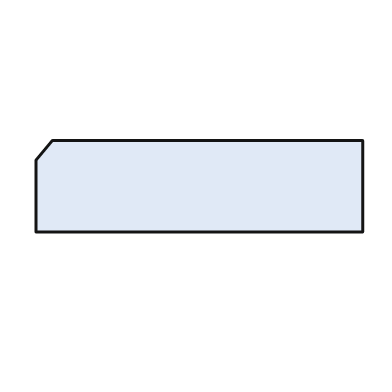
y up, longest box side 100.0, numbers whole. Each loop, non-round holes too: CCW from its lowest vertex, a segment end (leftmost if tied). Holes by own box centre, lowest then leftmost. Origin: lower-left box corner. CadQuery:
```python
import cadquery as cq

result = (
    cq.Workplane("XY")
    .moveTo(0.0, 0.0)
    .lineTo(100.0, 0.0)
    .lineTo(100.0, 28.0)
    .lineTo(5.0, 28.0)
    .lineTo(0.0, 22.0)
    .close()
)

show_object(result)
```